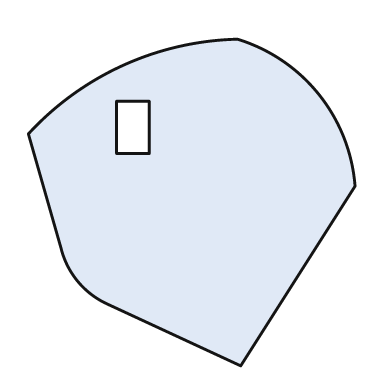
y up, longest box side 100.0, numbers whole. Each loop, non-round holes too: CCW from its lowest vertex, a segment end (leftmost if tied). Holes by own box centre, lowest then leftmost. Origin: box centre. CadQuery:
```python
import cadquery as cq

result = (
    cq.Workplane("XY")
    .moveTo(15.0, -50.0)
    .lineTo(50.0, 5.0)
    .threePointArc((39.0, 33.0), (14.0, 50.0))
    .threePointArc((-21.0, 42.0), (-50.0, 21.0))
    .lineTo(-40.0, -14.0)
    .threePointArc((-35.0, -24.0), (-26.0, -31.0))
    .close()
    .moveTo(-23.0, 15.0)
    .lineTo(-13.0, 15.0)
    .lineTo(-13.0, 31.0)
    .lineTo(-23.0, 31.0)
    .close()
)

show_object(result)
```